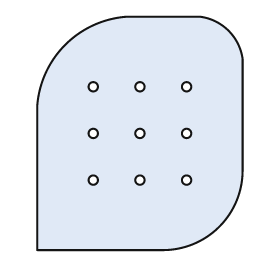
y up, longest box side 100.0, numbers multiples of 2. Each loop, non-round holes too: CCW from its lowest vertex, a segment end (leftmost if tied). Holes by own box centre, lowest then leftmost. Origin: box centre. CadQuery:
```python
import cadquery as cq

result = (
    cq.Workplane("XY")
    .moveTo(-44.0, -50.0)
    .lineTo(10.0, -50.0)
    .threePointArc((34.0, -40.0), (44.0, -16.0))
    .lineTo(44.0, 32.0)
    .threePointArc((38.0, 44.0), (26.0, 50.0))
    .lineTo(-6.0, 50.0)
    .threePointArc((-32.0, 38.0), (-44.0, 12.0))
    .close()
    .moveTo(-20.0, -20.0)
    .circle(2.0)
    .moveTo(0.0, -20.0)
    .circle(2.0)
    .moveTo(20.0, -20.0)
    .circle(2.0)
    .moveTo(-20.0, 0.0)
    .circle(2.0)
    .moveTo(0.0, 0.0)
    .circle(2.0)
    .moveTo(20.0, 0.0)
    .circle(2.0)
    .moveTo(-20.0, 20.0)
    .circle(2.0)
    .moveTo(0.0, 20.0)
    .circle(2.0)
    .moveTo(20.0, 20.0)
    .circle(2.0)
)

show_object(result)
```